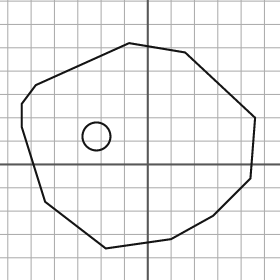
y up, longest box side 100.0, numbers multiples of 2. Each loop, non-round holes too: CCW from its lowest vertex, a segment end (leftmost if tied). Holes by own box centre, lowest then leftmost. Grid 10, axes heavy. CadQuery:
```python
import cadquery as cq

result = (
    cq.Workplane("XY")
    .moveTo(-18.0, -36.0)
    .lineTo(10.0, -32.0)
    .lineTo(28.0, -22.0)
    .lineTo(44.0, -6.0)
    .lineTo(46.0, 20.0)
    .lineTo(16.0, 48.0)
    .lineTo(-8.0, 52.0)
    .lineTo(-48.0, 34.0)
    .lineTo(-54.0, 26.0)
    .lineTo(-54.0, 16.0)
    .lineTo(-44.0, -16.0)
    .close()
    .moveTo(-22.0, 12.0)
    .circle(6.0)
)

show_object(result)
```